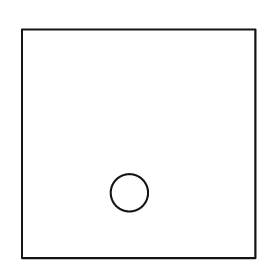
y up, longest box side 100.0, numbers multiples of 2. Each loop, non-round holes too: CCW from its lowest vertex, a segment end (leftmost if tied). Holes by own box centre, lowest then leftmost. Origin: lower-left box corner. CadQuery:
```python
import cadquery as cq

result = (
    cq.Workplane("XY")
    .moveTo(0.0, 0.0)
    .lineTo(100.0, 0.0)
    .lineTo(100.0, 98.0)
    .lineTo(0.0, 98.0)
    .close()
    .moveTo(46.0, 28.0)
    .circle(8.0)
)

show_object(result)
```